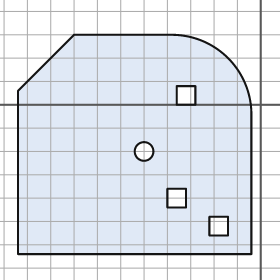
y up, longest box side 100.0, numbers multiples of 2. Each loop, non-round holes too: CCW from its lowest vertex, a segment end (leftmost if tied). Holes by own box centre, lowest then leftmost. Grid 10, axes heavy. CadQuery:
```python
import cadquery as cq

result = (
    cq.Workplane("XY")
    .moveTo(-104.0, -64.0)
    .lineTo(-4.0, -64.0)
    .lineTo(-4.0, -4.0)
    .threePointArc((-14.0, 20.0), (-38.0, 30.0))
    .lineTo(-80.0, 30.0)
    .lineTo(-104.0, 6.0)
    .close()
    .moveTo(-22.0, -56.0)
    .lineTo(-14.0, -56.0)
    .lineTo(-14.0, -48.0)
    .lineTo(-22.0, -48.0)
    .close()
    .moveTo(-40.0, -44.0)
    .lineTo(-32.0, -44.0)
    .lineTo(-32.0, -36.0)
    .lineTo(-40.0, -36.0)
    .close()
    .moveTo(-50.0, -20.0)
    .circle(4.0)
    .moveTo(-36.0, 0.0)
    .lineTo(-28.0, 0.0)
    .lineTo(-28.0, 8.0)
    .lineTo(-36.0, 8.0)
    .close()
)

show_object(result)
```